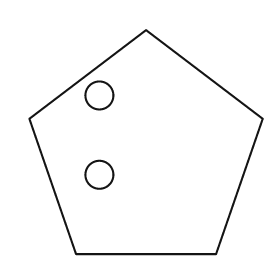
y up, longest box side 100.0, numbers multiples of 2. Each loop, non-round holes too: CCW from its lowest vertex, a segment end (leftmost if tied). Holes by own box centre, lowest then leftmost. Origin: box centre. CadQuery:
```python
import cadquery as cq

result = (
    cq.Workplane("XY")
    .moveTo(-30.0, -48.0)
    .lineTo(30.0, -48.0)
    .lineTo(50.0, 10.0)
    .lineTo(0.0, 48.0)
    .lineTo(-50.0, 10.0)
    .close()
    .moveTo(-20.0, -14.0)
    .circle(6.0)
    .moveTo(-20.0, 20.0)
    .circle(6.0)
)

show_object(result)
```